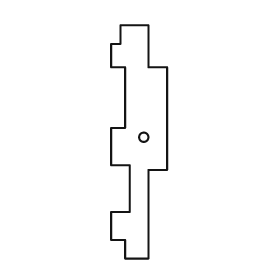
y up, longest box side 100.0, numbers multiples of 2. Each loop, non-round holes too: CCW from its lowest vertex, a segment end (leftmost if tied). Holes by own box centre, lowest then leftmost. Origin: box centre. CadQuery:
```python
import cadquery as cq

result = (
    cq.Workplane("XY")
    .moveTo(-6.0, -50.0)
    .lineTo(4.0, -50.0)
    .lineTo(4.0, -12.0)
    .lineTo(12.0, -12.0)
    .lineTo(12.0, 32.0)
    .lineTo(4.0, 32.0)
    .lineTo(4.0, 50.0)
    .lineTo(-8.0, 50.0)
    .lineTo(-8.0, 42.0)
    .lineTo(-12.0, 42.0)
    .lineTo(-12.0, 32.0)
    .lineTo(-6.0, 32.0)
    .lineTo(-6.0, 6.0)
    .lineTo(-12.0, 6.0)
    .lineTo(-12.0, -10.0)
    .lineTo(-4.0, -10.0)
    .lineTo(-4.0, -30.0)
    .lineTo(-12.0, -30.0)
    .lineTo(-12.0, -42.0)
    .lineTo(-6.0, -42.0)
    .close()
    .moveTo(2.0, 2.0)
    .circle(2.0)
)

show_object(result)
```